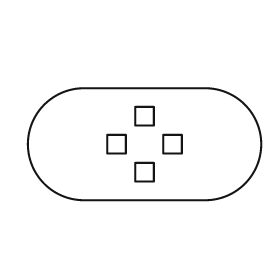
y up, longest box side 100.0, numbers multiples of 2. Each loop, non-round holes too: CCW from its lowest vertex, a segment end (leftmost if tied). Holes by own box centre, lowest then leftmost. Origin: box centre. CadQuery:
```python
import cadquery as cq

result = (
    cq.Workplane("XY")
    .moveTo(-26.0, -24.0)
    .lineTo(26.0, -24.0)
    .threePointArc((50.0, 0.0), (26.0, 24.0))
    .lineTo(-26.0, 24.0)
    .threePointArc((-50.0, 0.0), (-26.0, -24.0))
    .close()
    .moveTo(-4.0, -16.0)
    .lineTo(4.0, -16.0)
    .lineTo(4.0, -8.0)
    .lineTo(-4.0, -8.0)
    .close()
    .moveTo(-16.0, -4.0)
    .lineTo(-8.0, -4.0)
    .lineTo(-8.0, 4.0)
    .lineTo(-16.0, 4.0)
    .close()
    .moveTo(8.0, -4.0)
    .lineTo(16.0, -4.0)
    .lineTo(16.0, 4.0)
    .lineTo(8.0, 4.0)
    .close()
    .moveTo(-4.0, 8.0)
    .lineTo(4.0, 8.0)
    .lineTo(4.0, 16.0)
    .lineTo(-4.0, 16.0)
    .close()
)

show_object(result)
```